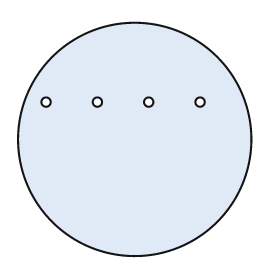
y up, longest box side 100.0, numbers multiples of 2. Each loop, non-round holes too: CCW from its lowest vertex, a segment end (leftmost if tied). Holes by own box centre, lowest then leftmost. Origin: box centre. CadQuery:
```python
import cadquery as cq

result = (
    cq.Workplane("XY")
    .moveTo(0.0, 0.0)
    .circle(50.0)
    .moveTo(-38.0, 16.0)
    .circle(2.0)
    .moveTo(-16.0, 16.0)
    .circle(2.0)
    .moveTo(6.0, 16.0)
    .circle(2.0)
    .moveTo(28.0, 16.0)
    .circle(2.0)
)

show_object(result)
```